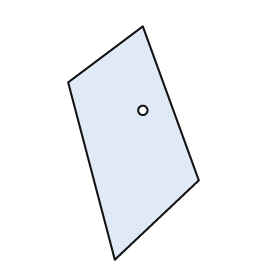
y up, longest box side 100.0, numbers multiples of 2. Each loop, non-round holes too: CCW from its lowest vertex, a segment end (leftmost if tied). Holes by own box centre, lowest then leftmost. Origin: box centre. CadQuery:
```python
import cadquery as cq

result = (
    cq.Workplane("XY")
    .moveTo(-8.0, -50.0)
    .lineTo(28.0, -16.0)
    .lineTo(4.0, 50.0)
    .lineTo(-28.0, 26.0)
    .close()
    .moveTo(4.0, 14.0)
    .circle(2.0)
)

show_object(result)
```